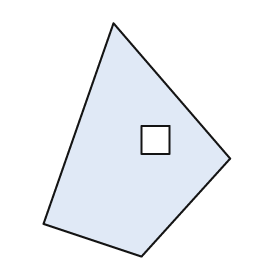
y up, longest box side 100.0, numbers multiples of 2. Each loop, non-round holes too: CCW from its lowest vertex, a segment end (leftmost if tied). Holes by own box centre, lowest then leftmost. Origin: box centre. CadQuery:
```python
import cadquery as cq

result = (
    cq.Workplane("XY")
    .moveTo(2.0, -50.0)
    .lineTo(40.0, -8.0)
    .lineTo(-10.0, 50.0)
    .lineTo(-40.0, -36.0)
    .close()
    .moveTo(2.0, -6.0)
    .lineTo(14.0, -6.0)
    .lineTo(14.0, 6.0)
    .lineTo(2.0, 6.0)
    .close()
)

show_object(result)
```